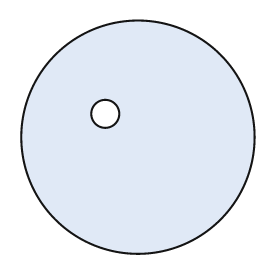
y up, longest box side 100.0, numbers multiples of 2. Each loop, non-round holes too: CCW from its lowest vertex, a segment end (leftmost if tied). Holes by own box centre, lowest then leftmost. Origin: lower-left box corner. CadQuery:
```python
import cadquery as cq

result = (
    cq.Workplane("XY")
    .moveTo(50.0, 50.0)
    .circle(50.0)
    .moveTo(36.0, 60.0)
    .circle(6.0)
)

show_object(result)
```